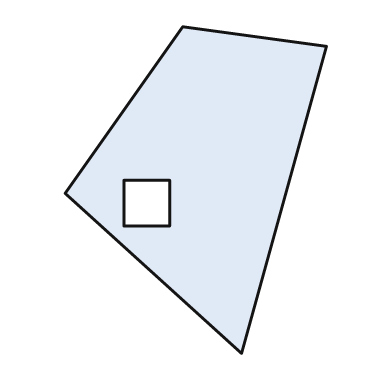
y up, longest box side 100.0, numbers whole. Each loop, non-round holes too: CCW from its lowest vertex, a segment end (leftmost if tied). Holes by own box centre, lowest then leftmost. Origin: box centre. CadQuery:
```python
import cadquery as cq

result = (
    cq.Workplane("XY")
    .moveTo(14.0, -50.0)
    .lineTo(40.0, 44.0)
    .lineTo(-4.0, 50.0)
    .lineTo(-40.0, -1.0)
    .close()
    .moveTo(-22.0, -11.0)
    .lineTo(-8.0, -11.0)
    .lineTo(-8.0, 3.0)
    .lineTo(-22.0, 3.0)
    .close()
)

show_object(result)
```